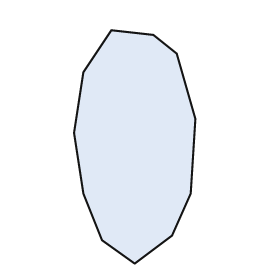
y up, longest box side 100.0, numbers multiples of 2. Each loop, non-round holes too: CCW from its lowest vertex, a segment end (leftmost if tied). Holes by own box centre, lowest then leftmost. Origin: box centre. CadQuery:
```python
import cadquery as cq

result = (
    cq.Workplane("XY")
    .moveTo(0.0, -50.0)
    .lineTo(16.0, -38.0)
    .lineTo(24.0, -20.0)
    .lineTo(26.0, 12.0)
    .lineTo(18.0, 40.0)
    .lineTo(8.0, 48.0)
    .lineTo(-10.0, 50.0)
    .lineTo(-22.0, 32.0)
    .lineTo(-26.0, 6.0)
    .lineTo(-22.0, -20.0)
    .lineTo(-14.0, -40.0)
    .close()
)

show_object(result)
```